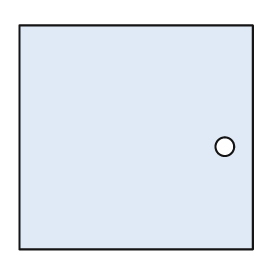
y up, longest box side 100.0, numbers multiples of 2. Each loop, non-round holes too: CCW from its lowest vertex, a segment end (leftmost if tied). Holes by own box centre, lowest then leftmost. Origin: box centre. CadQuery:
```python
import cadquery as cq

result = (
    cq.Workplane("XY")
    .moveTo(-50.0, -48.0)
    .lineTo(50.0, -48.0)
    .lineTo(50.0, 48.0)
    .lineTo(-50.0, 48.0)
    .close()
    .moveTo(38.0, -4.0)
    .circle(4.0)
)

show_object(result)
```